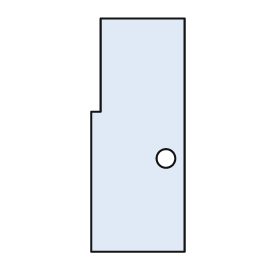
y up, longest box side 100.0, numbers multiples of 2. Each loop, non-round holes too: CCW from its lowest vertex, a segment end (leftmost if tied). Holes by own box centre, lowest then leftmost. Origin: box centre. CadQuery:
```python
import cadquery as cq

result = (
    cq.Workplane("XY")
    .moveTo(-20.0, -50.0)
    .lineTo(20.0, -50.0)
    .lineTo(20.0, 50.0)
    .lineTo(-16.0, 50.0)
    .lineTo(-16.0, 10.0)
    .lineTo(-20.0, 10.0)
    .close()
    .moveTo(12.0, -10.0)
    .circle(4.0)
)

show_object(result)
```